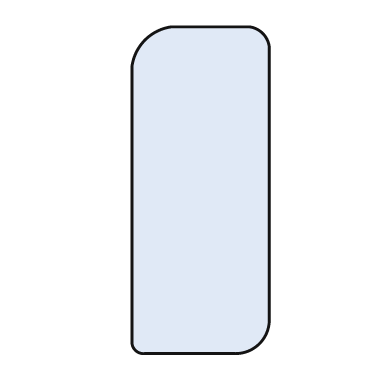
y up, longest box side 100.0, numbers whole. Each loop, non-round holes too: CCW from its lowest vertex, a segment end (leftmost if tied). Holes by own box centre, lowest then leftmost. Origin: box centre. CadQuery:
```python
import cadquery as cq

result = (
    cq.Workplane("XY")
    .moveTo(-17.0, -50.0)
    .lineTo(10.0, -50.0)
    .threePointArc((18.0, -47.0), (21.0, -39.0))
    .lineTo(21.0, 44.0)
    .threePointArc((19.0, 48.0), (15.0, 50.0))
    .lineTo(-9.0, 50.0)
    .threePointArc((-17.0, 46.0), (-21.0, 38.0))
    .lineTo(-21.0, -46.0)
    .threePointArc((-20.0, -49.0), (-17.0, -50.0))
    .close()
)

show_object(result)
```